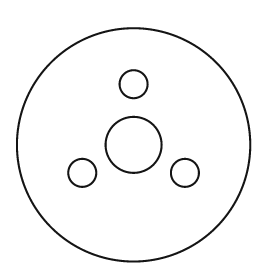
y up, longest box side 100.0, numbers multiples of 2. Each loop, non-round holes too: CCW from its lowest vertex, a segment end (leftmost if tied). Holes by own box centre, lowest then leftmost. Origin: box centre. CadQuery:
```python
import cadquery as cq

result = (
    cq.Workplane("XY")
    .moveTo(0.0, 0.0)
    .circle(50.0)
    .moveTo(-22.0, -12.0)
    .circle(6.0)
    .moveTo(22.0, -12.0)
    .circle(6.0)
    .moveTo(0.0, 0.0)
    .circle(12.0)
    .moveTo(0.0, 26.0)
    .circle(6.0)
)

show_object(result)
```